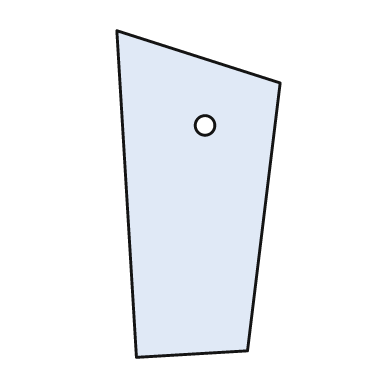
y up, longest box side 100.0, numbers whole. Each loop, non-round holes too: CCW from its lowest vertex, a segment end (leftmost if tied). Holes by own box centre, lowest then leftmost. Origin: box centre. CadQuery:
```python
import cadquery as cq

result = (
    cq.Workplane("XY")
    .moveTo(-19.0, -50.0)
    .lineTo(15.0, -48.0)
    .lineTo(25.0, 34.0)
    .lineTo(-25.0, 50.0)
    .close()
    .moveTo(2.0, 21.0)
    .circle(3.0)
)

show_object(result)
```